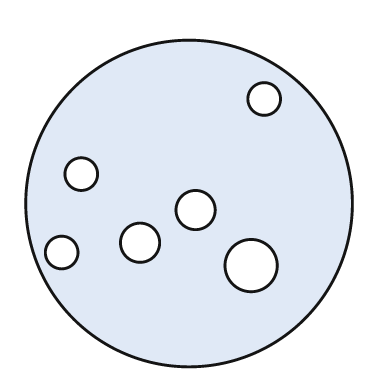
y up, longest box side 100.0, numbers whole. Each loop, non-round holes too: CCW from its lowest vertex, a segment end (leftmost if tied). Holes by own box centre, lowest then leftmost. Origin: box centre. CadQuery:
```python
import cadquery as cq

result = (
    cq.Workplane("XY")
    .moveTo(0.0, 0.0)
    .circle(50.0)
    .moveTo(19.0, -19.0)
    .circle(8.0)
    .moveTo(-39.0, -15.0)
    .circle(5.0)
    .moveTo(-15.0, -12.0)
    .circle(6.0)
    .moveTo(2.0, -2.0)
    .circle(6.0)
    .moveTo(-33.0, 9.0)
    .circle(5.0)
    .moveTo(23.0, 32.0)
    .circle(5.0)
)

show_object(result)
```